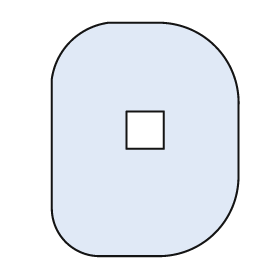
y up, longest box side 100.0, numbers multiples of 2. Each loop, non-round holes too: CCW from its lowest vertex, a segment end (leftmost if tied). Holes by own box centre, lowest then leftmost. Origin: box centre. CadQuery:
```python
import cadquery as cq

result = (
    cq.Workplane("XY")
    .moveTo(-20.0, -50.0)
    .lineTo(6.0, -50.0)
    .threePointArc((30.0, -40.0), (40.0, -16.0))
    .lineTo(40.0, 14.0)
    .threePointArc((30.0, 40.0), (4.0, 50.0))
    .lineTo(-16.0, 50.0)
    .threePointArc((-32.0, 42.0), (-40.0, 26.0))
    .lineTo(-40.0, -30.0)
    .threePointArc((-34.0, -44.0), (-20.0, -50.0))
    .close()
    .moveTo(-8.0, -4.0)
    .lineTo(8.0, -4.0)
    .lineTo(8.0, 12.0)
    .lineTo(-8.0, 12.0)
    .close()
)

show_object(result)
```